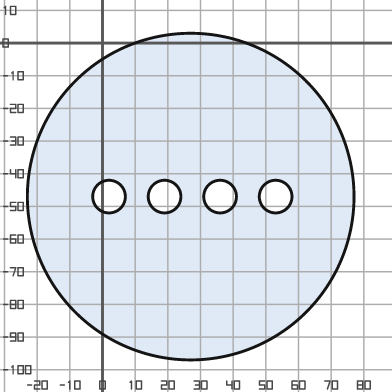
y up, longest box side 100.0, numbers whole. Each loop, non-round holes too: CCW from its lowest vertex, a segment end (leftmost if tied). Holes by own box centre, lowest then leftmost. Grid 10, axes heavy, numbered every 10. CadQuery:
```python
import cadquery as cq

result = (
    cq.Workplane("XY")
    .moveTo(27.0, -47.0)
    .circle(50.0)
    .moveTo(2.0, -47.0)
    .circle(5.0)
    .moveTo(19.0, -47.0)
    .circle(5.0)
    .moveTo(36.0, -47.0)
    .circle(5.0)
    .moveTo(53.0, -47.0)
    .circle(5.0)
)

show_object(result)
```